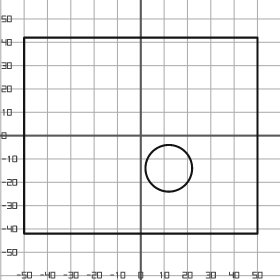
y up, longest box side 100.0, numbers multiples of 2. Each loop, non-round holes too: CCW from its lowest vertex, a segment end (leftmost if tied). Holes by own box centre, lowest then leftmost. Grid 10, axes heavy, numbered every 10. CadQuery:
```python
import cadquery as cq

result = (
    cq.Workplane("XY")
    .moveTo(-50.0, -42.0)
    .lineTo(50.0, -42.0)
    .lineTo(50.0, 42.0)
    .lineTo(-50.0, 42.0)
    .close()
    .moveTo(12.0, -14.0)
    .circle(10.0)
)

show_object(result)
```